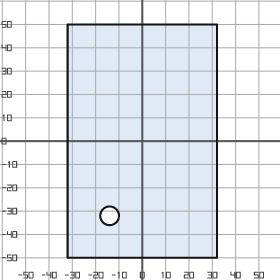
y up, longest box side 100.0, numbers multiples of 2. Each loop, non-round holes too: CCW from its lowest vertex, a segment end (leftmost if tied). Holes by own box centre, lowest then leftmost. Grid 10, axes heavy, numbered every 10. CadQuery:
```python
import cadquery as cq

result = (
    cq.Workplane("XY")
    .moveTo(-32.0, -50.0)
    .lineTo(32.0, -50.0)
    .lineTo(32.0, 50.0)
    .lineTo(-32.0, 50.0)
    .close()
    .moveTo(-14.0, -32.0)
    .circle(4.0)
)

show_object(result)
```